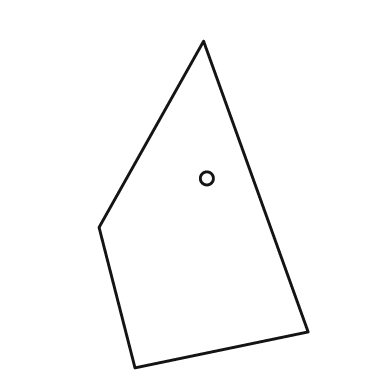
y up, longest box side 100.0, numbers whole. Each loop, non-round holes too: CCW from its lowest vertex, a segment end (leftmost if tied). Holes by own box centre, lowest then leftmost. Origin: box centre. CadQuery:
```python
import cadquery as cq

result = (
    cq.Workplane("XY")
    .moveTo(-21.0, -50.0)
    .lineTo(32.0, -39.0)
    .lineTo(0.0, 50.0)
    .lineTo(-32.0, -7.0)
    .close()
    .moveTo(1.0, 8.0)
    .circle(2.0)
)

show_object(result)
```